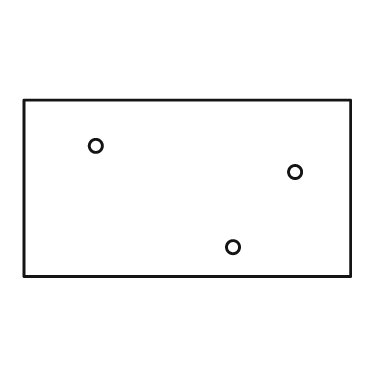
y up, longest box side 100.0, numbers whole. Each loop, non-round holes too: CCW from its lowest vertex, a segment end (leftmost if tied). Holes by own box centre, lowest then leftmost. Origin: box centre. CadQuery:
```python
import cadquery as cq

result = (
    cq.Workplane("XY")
    .moveTo(-50.0, -27.0)
    .lineTo(50.0, -27.0)
    .lineTo(50.0, 27.0)
    .lineTo(-50.0, 27.0)
    .close()
    .moveTo(14.0, -18.0)
    .circle(2.0)
    .moveTo(33.0, 5.0)
    .circle(2.0)
    .moveTo(-28.0, 13.0)
    .circle(2.0)
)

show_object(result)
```